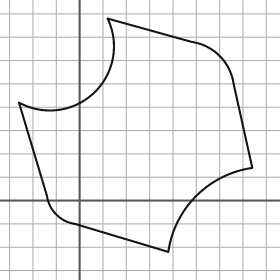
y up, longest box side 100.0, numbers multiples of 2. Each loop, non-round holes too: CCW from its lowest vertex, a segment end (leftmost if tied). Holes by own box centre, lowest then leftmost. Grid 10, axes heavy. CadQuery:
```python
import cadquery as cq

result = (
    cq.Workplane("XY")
    .moveTo(38.0, -22.0)
    .threePointArc((50.0, 2.0), (74.0, 14.0))
    .lineTo(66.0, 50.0)
    .threePointArc((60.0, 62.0), (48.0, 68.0))
    .lineTo(12.0, 78.0)
    .threePointArc((6.0, 46.0), (-26.0, 42.0))
    .lineTo(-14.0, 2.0)
    .threePointArc((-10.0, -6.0), (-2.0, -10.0))
    .close()
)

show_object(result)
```